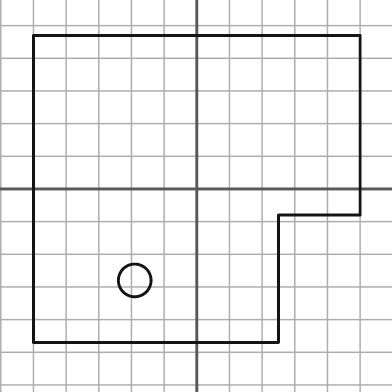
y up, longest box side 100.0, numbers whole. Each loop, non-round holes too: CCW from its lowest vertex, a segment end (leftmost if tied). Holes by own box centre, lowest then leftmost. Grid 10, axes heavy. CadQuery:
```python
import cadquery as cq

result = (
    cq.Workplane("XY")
    .moveTo(-50.0, -47.0)
    .lineTo(25.0, -47.0)
    .lineTo(25.0, -8.0)
    .lineTo(50.0, -8.0)
    .lineTo(50.0, 47.0)
    .lineTo(-50.0, 47.0)
    .close()
    .moveTo(-19.0, -28.0)
    .circle(5.0)
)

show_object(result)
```